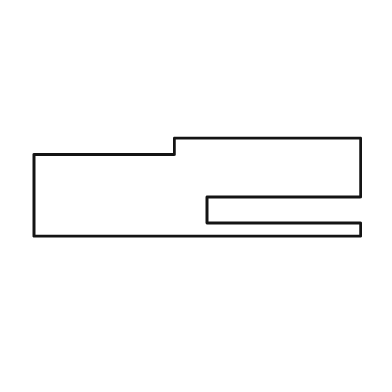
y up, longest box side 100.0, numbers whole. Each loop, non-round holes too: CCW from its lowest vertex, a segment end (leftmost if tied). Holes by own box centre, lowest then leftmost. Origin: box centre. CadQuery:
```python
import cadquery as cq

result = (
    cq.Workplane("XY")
    .moveTo(-50.0, -15.0)
    .lineTo(50.0, -15.0)
    .lineTo(50.0, -11.0)
    .lineTo(3.0, -11.0)
    .lineTo(3.0, -3.0)
    .lineTo(50.0, -3.0)
    .lineTo(50.0, 15.0)
    .lineTo(-7.0, 15.0)
    .lineTo(-7.0, 10.0)
    .lineTo(-50.0, 10.0)
    .close()
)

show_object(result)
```